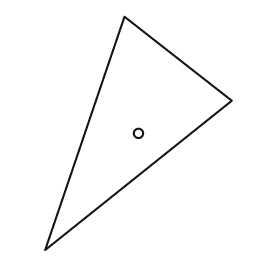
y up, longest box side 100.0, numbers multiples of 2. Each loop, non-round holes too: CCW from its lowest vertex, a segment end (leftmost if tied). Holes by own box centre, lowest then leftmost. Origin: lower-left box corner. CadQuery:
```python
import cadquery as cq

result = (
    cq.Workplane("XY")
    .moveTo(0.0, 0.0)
    .lineTo(80.0, 64.0)
    .lineTo(34.0, 100.0)
    .close()
    .moveTo(40.0, 50.0)
    .circle(2.0)
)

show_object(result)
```